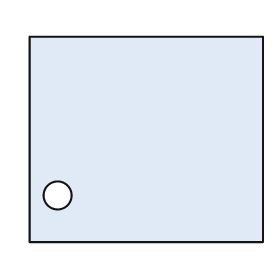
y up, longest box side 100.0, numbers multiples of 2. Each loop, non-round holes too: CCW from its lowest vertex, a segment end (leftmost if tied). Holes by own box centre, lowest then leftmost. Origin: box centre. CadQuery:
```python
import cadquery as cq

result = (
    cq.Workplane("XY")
    .moveTo(-50.0, -44.0)
    .lineTo(50.0, -44.0)
    .lineTo(50.0, 44.0)
    .lineTo(-50.0, 44.0)
    .close()
    .moveTo(-38.0, -24.0)
    .circle(6.0)
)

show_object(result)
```